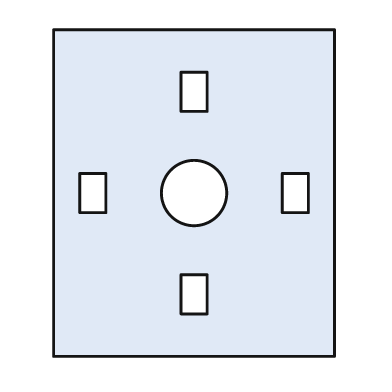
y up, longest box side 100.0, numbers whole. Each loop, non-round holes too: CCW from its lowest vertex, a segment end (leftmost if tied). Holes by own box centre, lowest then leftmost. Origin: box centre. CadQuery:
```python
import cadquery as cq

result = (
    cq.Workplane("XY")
    .moveTo(-43.0, -50.0)
    .lineTo(43.0, -50.0)
    .lineTo(43.0, 50.0)
    .lineTo(-43.0, 50.0)
    .close()
    .moveTo(-4.0, -37.0)
    .lineTo(4.0, -37.0)
    .lineTo(4.0, -25.0)
    .lineTo(-4.0, -25.0)
    .close()
    .moveTo(-35.0, -6.0)
    .lineTo(-27.0, -6.0)
    .lineTo(-27.0, 6.0)
    .lineTo(-35.0, 6.0)
    .close()
    .moveTo(0.0, 0.0)
    .circle(10.0)
    .moveTo(27.0, -6.0)
    .lineTo(35.0, -6.0)
    .lineTo(35.0, 6.0)
    .lineTo(27.0, 6.0)
    .close()
    .moveTo(-4.0, 25.0)
    .lineTo(4.0, 25.0)
    .lineTo(4.0, 37.0)
    .lineTo(-4.0, 37.0)
    .close()
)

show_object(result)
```